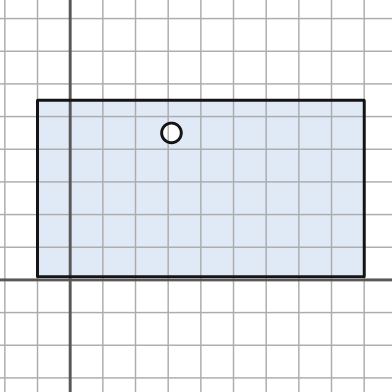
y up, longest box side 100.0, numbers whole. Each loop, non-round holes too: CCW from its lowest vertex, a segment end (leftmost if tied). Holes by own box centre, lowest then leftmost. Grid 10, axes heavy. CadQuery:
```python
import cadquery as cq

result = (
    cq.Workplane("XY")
    .moveTo(-10.0, 1.0)
    .lineTo(90.0, 1.0)
    .lineTo(90.0, 55.0)
    .lineTo(-10.0, 55.0)
    .close()
    .moveTo(31.0, 45.0)
    .circle(3.0)
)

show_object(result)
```